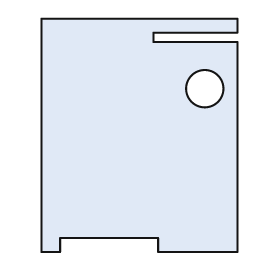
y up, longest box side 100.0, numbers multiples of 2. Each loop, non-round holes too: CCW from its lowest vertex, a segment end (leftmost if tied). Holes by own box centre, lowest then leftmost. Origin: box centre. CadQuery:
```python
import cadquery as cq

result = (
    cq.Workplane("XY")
    .moveTo(-42.0, -50.0)
    .lineTo(-34.0, -50.0)
    .lineTo(-34.0, -44.0)
    .lineTo(8.0, -44.0)
    .lineTo(8.0, -50.0)
    .lineTo(42.0, -50.0)
    .lineTo(42.0, 40.0)
    .lineTo(6.0, 40.0)
    .lineTo(6.0, 44.0)
    .lineTo(42.0, 44.0)
    .lineTo(42.0, 50.0)
    .lineTo(-42.0, 50.0)
    .close()
    .moveTo(28.0, 20.0)
    .circle(8.0)
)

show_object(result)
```